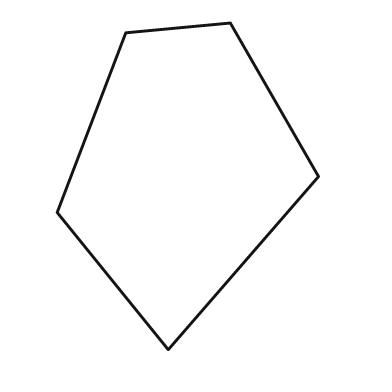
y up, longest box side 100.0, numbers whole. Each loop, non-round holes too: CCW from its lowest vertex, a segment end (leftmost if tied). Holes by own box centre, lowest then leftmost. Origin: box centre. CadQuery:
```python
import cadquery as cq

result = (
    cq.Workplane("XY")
    .moveTo(-6.0, -50.0)
    .lineTo(40.0, 3.0)
    .lineTo(13.0, 50.0)
    .lineTo(-19.0, 47.0)
    .lineTo(-40.0, -8.0)
    .close()
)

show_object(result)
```